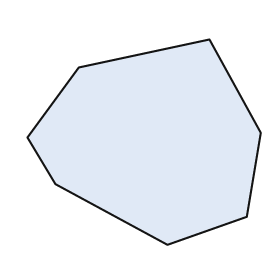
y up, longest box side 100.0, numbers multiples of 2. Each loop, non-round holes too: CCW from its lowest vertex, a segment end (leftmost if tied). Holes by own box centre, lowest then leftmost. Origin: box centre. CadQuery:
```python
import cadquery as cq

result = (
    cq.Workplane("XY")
    .moveTo(10.0, -44.0)
    .lineTo(44.0, -32.0)
    .lineTo(50.0, 4.0)
    .lineTo(28.0, 44.0)
    .lineTo(-28.0, 32.0)
    .lineTo(-50.0, 2.0)
    .lineTo(-38.0, -18.0)
    .close()
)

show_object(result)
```